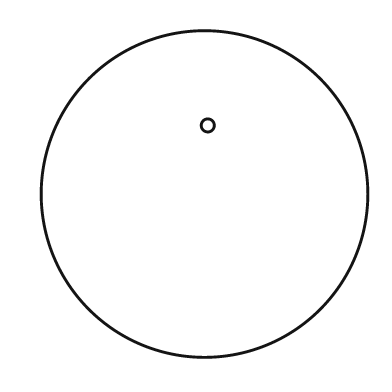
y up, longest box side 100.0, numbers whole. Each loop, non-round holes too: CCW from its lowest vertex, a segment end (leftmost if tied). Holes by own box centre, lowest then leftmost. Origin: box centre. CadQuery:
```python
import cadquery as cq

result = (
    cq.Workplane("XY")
    .moveTo(0.0, 0.0)
    .circle(50.0)
    .moveTo(1.0, 21.0)
    .circle(2.0)
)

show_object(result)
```